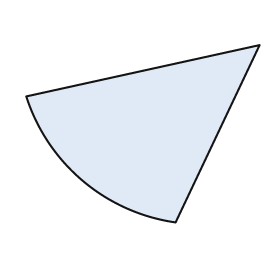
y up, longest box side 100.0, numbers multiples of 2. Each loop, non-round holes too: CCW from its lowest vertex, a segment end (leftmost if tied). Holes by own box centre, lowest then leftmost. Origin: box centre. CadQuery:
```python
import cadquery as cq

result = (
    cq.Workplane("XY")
    .moveTo(14.0, -38.0)
    .lineTo(50.0, 38.0)
    .lineTo(-50.0, 16.0)
    .threePointArc((-26.0, -20.0), (14.0, -38.0))
    .close()
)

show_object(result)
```